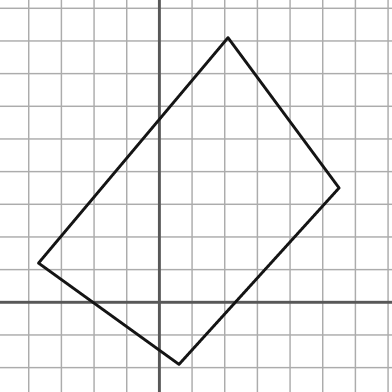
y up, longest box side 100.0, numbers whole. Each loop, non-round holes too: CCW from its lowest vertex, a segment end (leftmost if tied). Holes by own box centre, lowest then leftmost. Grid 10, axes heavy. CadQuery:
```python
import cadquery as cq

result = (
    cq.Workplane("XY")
    .moveTo(6.0, -19.0)
    .lineTo(55.0, 35.0)
    .lineTo(21.0, 81.0)
    .lineTo(-37.0, 12.0)
    .close()
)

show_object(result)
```